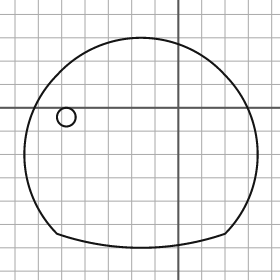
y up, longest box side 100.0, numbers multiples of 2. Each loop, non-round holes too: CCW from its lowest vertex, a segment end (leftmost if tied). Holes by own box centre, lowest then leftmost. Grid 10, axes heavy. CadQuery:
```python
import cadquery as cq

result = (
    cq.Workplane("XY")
    .moveTo(-52.0, -54.0)
    .threePointArc((-16.0, -60.0), (20.0, -54.0))
    .threePointArc((34.0, -20.0), (20.0, 14.0))
    .threePointArc((-16.0, 30.0), (-52.0, 14.0))
    .threePointArc((-66.0, -20.0), (-52.0, -54.0))
    .close()
    .moveTo(-48.0, -4.0)
    .circle(4.0)
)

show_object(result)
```